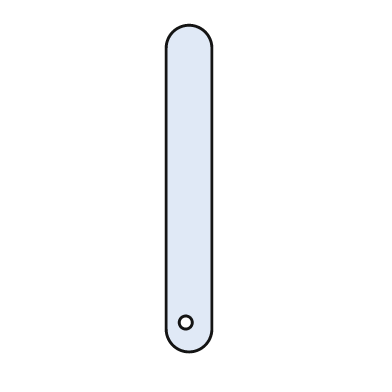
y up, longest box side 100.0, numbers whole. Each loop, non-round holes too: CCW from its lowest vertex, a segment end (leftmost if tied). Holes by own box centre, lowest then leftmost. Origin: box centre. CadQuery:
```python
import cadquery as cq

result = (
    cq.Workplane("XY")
    .moveTo(-7.0, -43.0)
    .threePointArc((0.0, -50.0), (7.0, -43.0))
    .lineTo(7.0, 43.0)
    .threePointArc((0.0, 50.0), (-7.0, 43.0))
    .close()
    .moveTo(-1.0, -41.0)
    .circle(2.0)
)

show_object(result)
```